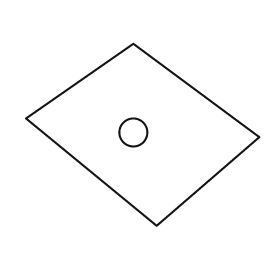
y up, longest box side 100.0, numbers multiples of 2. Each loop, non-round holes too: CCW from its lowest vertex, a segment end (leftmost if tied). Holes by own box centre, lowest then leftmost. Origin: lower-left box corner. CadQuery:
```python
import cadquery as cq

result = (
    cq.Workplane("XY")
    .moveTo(56.0, 0.0)
    .lineTo(100.0, 38.0)
    .lineTo(46.0, 78.0)
    .lineTo(0.0, 46.0)
    .close()
    .moveTo(46.0, 40.0)
    .circle(6.0)
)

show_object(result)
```